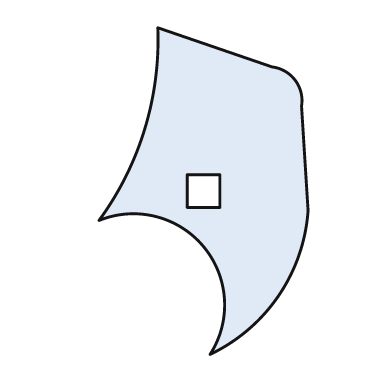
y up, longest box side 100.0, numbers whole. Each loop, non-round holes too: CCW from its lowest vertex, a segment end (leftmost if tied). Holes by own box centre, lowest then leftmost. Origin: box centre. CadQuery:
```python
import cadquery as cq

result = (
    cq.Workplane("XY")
    .moveTo(2.0, -50.0)
    .threePointArc((23.0, -32.0), (32.0, -6.0))
    .lineTo(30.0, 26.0)
    .threePointArc((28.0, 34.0), (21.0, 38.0))
    .lineTo(-14.0, 50.0)
    .threePointArc((-18.0, 19.0), (-32.0, -9.0))
    .threePointArc((0.0, -17.0), (2.0, -50.0))
    .close()
    .moveTo(-5.0, -5.0)
    .lineTo(5.0, -5.0)
    .lineTo(5.0, 5.0)
    .lineTo(-5.0, 5.0)
    .close()
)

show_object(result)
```